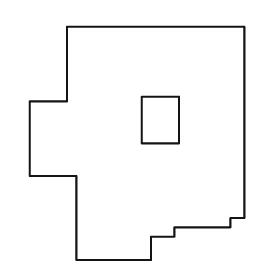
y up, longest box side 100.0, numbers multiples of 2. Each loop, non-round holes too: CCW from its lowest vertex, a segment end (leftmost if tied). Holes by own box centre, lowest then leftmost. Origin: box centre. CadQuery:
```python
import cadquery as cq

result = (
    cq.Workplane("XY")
    .moveTo(-26.0, -50.0)
    .lineTo(6.0, -50.0)
    .lineTo(6.0, -40.0)
    .lineTo(16.0, -40.0)
    .lineTo(16.0, -36.0)
    .lineTo(40.0, -36.0)
    .lineTo(40.0, -32.0)
    .lineTo(46.0, -32.0)
    .lineTo(46.0, 50.0)
    .lineTo(-30.0, 50.0)
    .lineTo(-30.0, 18.0)
    .lineTo(-46.0, 18.0)
    .lineTo(-46.0, -14.0)
    .lineTo(-26.0, -14.0)
    .close()
    .moveTo(2.0, 0.0)
    .lineTo(18.0, 0.0)
    .lineTo(18.0, 20.0)
    .lineTo(2.0, 20.0)
    .close()
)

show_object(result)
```